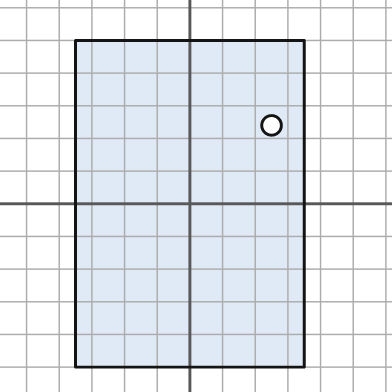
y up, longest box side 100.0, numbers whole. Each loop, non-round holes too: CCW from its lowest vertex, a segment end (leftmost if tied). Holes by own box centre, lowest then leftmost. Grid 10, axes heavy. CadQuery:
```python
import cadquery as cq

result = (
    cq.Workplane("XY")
    .moveTo(-35.0, -50.0)
    .lineTo(35.0, -50.0)
    .lineTo(35.0, 50.0)
    .lineTo(-35.0, 50.0)
    .close()
    .moveTo(25.0, 24.0)
    .circle(3.0)
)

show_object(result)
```